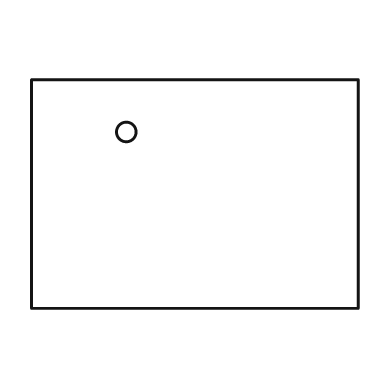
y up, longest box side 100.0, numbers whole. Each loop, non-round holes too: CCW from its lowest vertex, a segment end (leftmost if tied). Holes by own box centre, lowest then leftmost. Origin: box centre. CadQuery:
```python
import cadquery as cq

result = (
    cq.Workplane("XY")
    .moveTo(-50.0, -35.0)
    .lineTo(50.0, -35.0)
    .lineTo(50.0, 35.0)
    .lineTo(-50.0, 35.0)
    .close()
    .moveTo(-21.0, 19.0)
    .circle(3.0)
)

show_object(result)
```